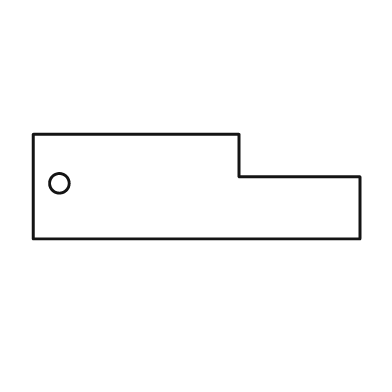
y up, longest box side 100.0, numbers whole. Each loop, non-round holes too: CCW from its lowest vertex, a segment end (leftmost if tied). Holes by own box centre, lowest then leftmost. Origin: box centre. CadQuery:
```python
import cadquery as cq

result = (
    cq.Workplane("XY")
    .moveTo(-50.0, -16.0)
    .lineTo(50.0, -16.0)
    .lineTo(50.0, 3.0)
    .lineTo(13.0, 3.0)
    .lineTo(13.0, 16.0)
    .lineTo(-50.0, 16.0)
    .close()
    .moveTo(-42.0, 1.0)
    .circle(3.0)
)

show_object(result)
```